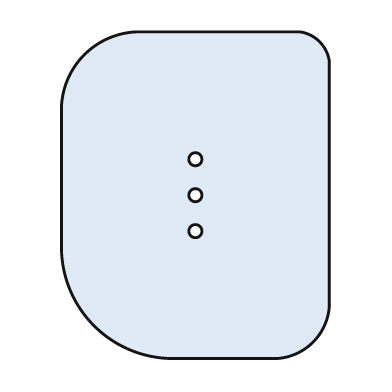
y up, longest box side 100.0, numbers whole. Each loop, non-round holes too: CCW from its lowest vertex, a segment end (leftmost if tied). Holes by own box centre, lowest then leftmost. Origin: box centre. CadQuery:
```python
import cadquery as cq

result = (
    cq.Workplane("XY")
    .moveTo(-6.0, -50.0)
    .lineTo(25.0, -50.0)
    .threePointArc((36.0, -45.0), (41.0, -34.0))
    .lineTo(41.0, 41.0)
    .threePointArc((38.0, 47.0), (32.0, 50.0))
    .lineTo(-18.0, 50.0)
    .threePointArc((-34.0, 43.0), (-41.0, 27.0))
    .lineTo(-41.0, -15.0)
    .threePointArc((-31.0, -40.0), (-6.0, -50.0))
    .close()
    .moveTo(0.0, -11.0)
    .circle(2.0)
    .moveTo(0.0, 0.0)
    .circle(2.0)
    .moveTo(0.0, 11.0)
    .circle(2.0)
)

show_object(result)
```